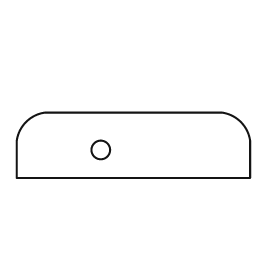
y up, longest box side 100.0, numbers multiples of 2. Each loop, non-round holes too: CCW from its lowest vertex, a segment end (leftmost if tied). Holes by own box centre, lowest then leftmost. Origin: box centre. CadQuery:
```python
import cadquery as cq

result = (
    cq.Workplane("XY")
    .moveTo(-50.0, -14.0)
    .lineTo(50.0, -14.0)
    .lineTo(50.0, 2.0)
    .threePointArc((46.0, 10.0), (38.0, 14.0))
    .lineTo(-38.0, 14.0)
    .threePointArc((-46.0, 10.0), (-50.0, 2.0))
    .close()
    .moveTo(-14.0, -2.0)
    .circle(4.0)
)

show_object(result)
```